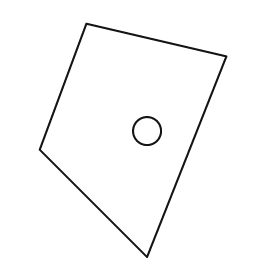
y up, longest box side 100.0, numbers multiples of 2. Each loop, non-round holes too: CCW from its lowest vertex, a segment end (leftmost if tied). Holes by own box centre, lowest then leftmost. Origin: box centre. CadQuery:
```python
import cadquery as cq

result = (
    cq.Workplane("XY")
    .moveTo(6.0, -50.0)
    .lineTo(40.0, 36.0)
    .lineTo(-20.0, 50.0)
    .lineTo(-40.0, -4.0)
    .close()
    .moveTo(6.0, 4.0)
    .circle(6.0)
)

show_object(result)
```